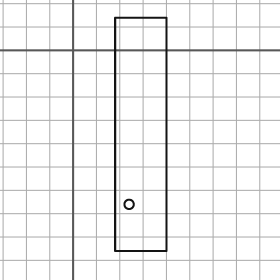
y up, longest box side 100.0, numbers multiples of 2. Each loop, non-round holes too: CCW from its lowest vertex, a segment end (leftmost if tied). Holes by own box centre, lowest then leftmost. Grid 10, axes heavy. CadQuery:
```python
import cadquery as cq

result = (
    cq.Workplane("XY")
    .moveTo(18.0, -86.0)
    .lineTo(40.0, -86.0)
    .lineTo(40.0, 14.0)
    .lineTo(18.0, 14.0)
    .close()
    .moveTo(24.0, -66.0)
    .circle(2.0)
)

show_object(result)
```